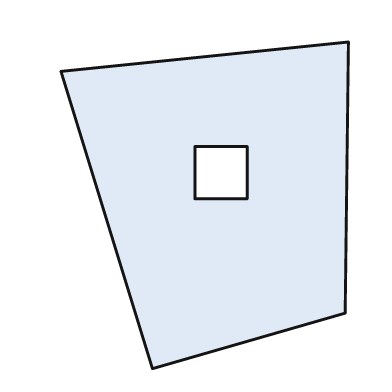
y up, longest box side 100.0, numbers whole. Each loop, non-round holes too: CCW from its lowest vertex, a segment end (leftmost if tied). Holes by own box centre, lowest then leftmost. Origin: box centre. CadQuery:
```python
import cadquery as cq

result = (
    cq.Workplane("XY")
    .moveTo(-16.0, -50.0)
    .lineTo(43.0, -33.0)
    .lineTo(44.0, 50.0)
    .lineTo(-44.0, 41.0)
    .close()
    .moveTo(-3.0, 2.0)
    .lineTo(13.0, 2.0)
    .lineTo(13.0, 18.0)
    .lineTo(-3.0, 18.0)
    .close()
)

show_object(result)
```